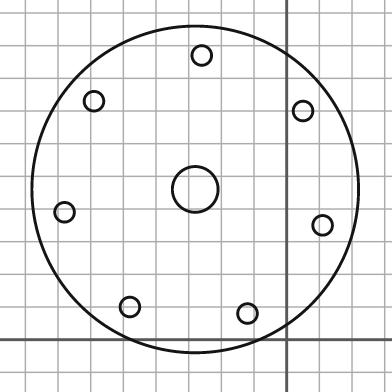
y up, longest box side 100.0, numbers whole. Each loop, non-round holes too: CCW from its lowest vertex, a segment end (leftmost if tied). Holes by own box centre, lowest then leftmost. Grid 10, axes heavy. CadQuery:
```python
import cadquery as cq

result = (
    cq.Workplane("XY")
    .moveTo(-28.0, 46.0)
    .circle(50.0)
    .moveTo(-12.0, 8.0)
    .circle(3.0)
    .moveTo(-48.0, 10.0)
    .circle(3.0)
    .moveTo(11.0, 35.0)
    .circle(3.0)
    .moveTo(-68.0, 39.0)
    .circle(3.0)
    .moveTo(-28.0, 46.0)
    .circle(7.0)
    .moveTo(5.0, 70.0)
    .circle(3.0)
    .moveTo(-59.0, 73.0)
    .circle(3.0)
    .moveTo(-26.0, 87.0)
    .circle(3.0)
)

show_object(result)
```